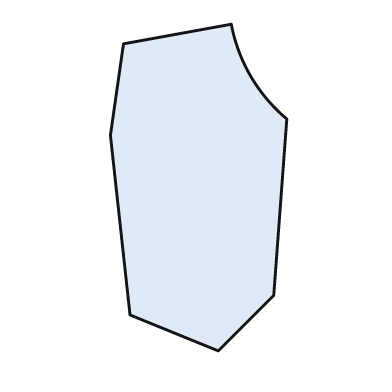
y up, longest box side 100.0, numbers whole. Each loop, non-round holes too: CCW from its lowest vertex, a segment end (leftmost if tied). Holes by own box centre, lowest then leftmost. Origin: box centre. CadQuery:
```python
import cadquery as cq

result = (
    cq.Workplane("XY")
    .moveTo(6.0, -50.0)
    .lineTo(23.0, -33.0)
    .lineTo(27.0, 21.0)
    .threePointArc((16.0, 34.0), (10.0, 50.0))
    .lineTo(-23.0, 44.0)
    .lineTo(-27.0, 16.0)
    .lineTo(-21.0, -39.0)
    .close()
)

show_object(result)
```